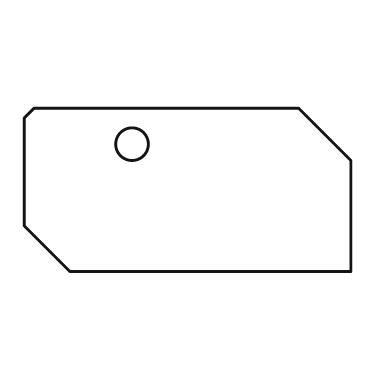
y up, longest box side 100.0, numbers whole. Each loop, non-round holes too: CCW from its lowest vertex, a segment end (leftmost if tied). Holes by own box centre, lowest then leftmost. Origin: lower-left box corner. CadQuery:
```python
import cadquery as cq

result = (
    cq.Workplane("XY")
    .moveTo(14.0, 0.0)
    .lineTo(100.0, 0.0)
    .lineTo(100.0, 34.0)
    .lineTo(84.0, 50.0)
    .lineTo(3.0, 50.0)
    .lineTo(0.0, 47.0)
    .lineTo(0.0, 14.0)
    .close()
    .moveTo(33.0, 39.0)
    .circle(5.0)
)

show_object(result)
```